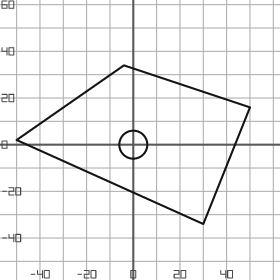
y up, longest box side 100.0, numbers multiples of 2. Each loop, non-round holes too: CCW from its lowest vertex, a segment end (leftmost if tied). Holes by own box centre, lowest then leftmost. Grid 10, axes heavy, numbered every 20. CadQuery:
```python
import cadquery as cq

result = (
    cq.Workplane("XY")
    .moveTo(30.0, -34.0)
    .lineTo(50.0, 16.0)
    .lineTo(-4.0, 34.0)
    .lineTo(-50.0, 2.0)
    .close()
    .moveTo(0.0, 0.0)
    .circle(6.0)
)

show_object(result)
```